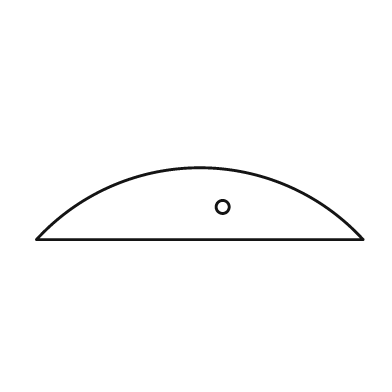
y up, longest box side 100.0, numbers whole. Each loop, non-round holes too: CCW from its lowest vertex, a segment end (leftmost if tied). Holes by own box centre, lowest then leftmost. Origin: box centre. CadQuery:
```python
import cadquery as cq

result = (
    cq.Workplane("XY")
    .moveTo(-50.0, -11.0)
    .lineTo(50.0, -11.0)
    .threePointArc((0.0, 11.0), (-50.0, -11.0))
    .close()
    .moveTo(7.0, -1.0)
    .circle(2.0)
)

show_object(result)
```